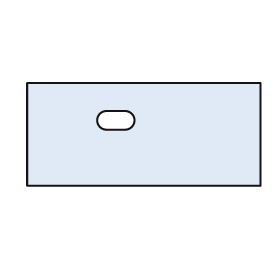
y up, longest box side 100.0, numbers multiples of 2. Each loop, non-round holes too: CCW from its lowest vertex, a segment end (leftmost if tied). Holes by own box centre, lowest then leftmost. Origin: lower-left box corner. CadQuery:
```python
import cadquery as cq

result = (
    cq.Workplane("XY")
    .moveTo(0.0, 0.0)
    .lineTo(100.0, 0.0)
    .lineTo(100.0, 44.0)
    .lineTo(0.0, 44.0)
    .close()
    .moveTo(34.0, 24.0)
    .lineTo(42.0, 24.0)
    .threePointArc((46.0, 28.0), (42.0, 32.0))
    .lineTo(34.0, 32.0)
    .threePointArc((30.0, 28.0), (34.0, 24.0))
    .close()
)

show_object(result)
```